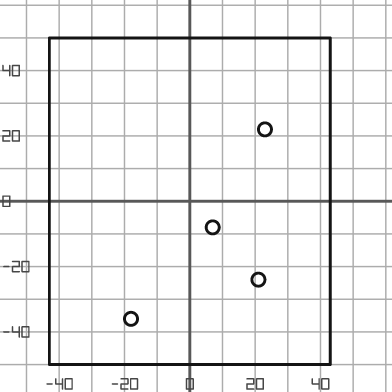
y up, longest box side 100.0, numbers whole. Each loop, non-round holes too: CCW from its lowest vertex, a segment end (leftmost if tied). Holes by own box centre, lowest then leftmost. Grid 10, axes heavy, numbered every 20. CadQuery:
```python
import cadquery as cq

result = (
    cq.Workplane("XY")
    .moveTo(-43.0, -50.0)
    .lineTo(43.0, -50.0)
    .lineTo(43.0, 50.0)
    .lineTo(-43.0, 50.0)
    .close()
    .moveTo(-18.0, -36.0)
    .circle(2.0)
    .moveTo(21.0, -24.0)
    .circle(2.0)
    .moveTo(7.0, -8.0)
    .circle(2.0)
    .moveTo(23.0, 22.0)
    .circle(2.0)
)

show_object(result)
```